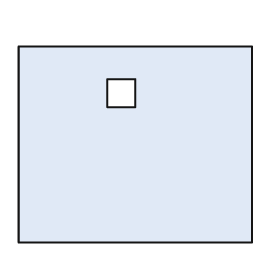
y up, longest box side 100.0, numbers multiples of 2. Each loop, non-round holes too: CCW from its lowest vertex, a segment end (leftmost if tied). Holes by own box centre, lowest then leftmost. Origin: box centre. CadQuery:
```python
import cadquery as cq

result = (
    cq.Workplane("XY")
    .moveTo(-50.0, -42.0)
    .lineTo(50.0, -42.0)
    .lineTo(50.0, 42.0)
    .lineTo(-50.0, 42.0)
    .close()
    .moveTo(-12.0, 16.0)
    .lineTo(0.0, 16.0)
    .lineTo(0.0, 28.0)
    .lineTo(-12.0, 28.0)
    .close()
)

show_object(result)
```